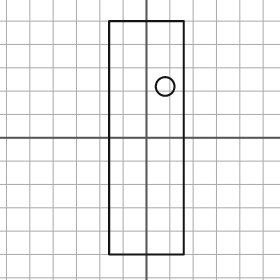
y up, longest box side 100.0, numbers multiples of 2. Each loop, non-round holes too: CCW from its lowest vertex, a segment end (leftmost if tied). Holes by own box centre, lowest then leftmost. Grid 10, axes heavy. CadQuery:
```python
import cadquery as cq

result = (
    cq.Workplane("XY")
    .moveTo(-16.0, -50.0)
    .lineTo(16.0, -50.0)
    .lineTo(16.0, 50.0)
    .lineTo(-16.0, 50.0)
    .close()
    .moveTo(8.0, 22.0)
    .circle(4.0)
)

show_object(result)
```